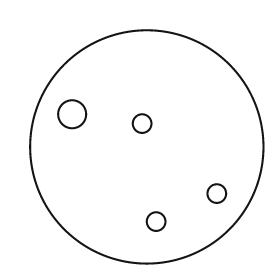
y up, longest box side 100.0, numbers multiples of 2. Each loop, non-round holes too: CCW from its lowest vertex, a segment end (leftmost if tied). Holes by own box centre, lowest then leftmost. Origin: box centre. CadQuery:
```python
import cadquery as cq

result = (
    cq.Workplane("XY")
    .moveTo(0.0, 0.0)
    .circle(50.0)
    .moveTo(4.0, -32.0)
    .circle(4.0)
    .moveTo(30.0, -20.0)
    .circle(4.0)
    .moveTo(-2.0, 10.0)
    .circle(4.0)
    .moveTo(-32.0, 14.0)
    .circle(6.0)
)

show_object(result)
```